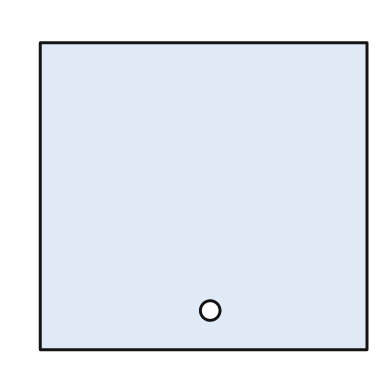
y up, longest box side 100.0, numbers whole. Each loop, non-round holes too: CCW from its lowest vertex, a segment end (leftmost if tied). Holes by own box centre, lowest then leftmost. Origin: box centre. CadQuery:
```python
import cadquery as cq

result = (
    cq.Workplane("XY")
    .moveTo(-50.0, -47.0)
    .lineTo(50.0, -47.0)
    .lineTo(50.0, 47.0)
    .lineTo(-50.0, 47.0)
    .close()
    .moveTo(2.0, -35.0)
    .circle(3.0)
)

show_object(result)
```